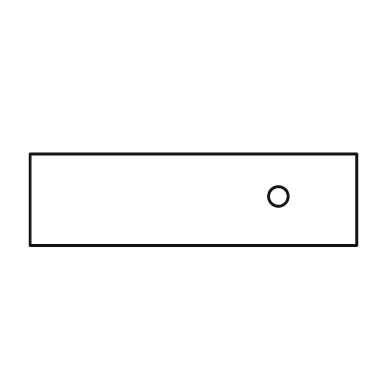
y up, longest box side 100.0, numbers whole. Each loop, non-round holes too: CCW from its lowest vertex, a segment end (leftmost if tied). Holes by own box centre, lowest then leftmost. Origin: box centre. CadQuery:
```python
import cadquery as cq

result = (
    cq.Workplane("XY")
    .moveTo(-50.0, -14.0)
    .lineTo(50.0, -14.0)
    .lineTo(50.0, 14.0)
    .lineTo(-50.0, 14.0)
    .close()
    .moveTo(26.0, 1.0)
    .circle(3.0)
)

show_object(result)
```